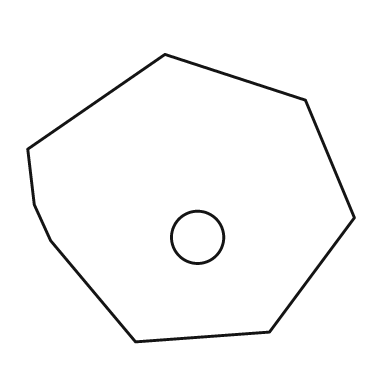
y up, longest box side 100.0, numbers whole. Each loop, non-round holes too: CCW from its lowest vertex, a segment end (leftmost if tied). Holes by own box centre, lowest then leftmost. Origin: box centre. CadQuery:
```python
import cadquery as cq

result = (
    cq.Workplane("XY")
    .moveTo(-17.0, -44.0)
    .lineTo(24.0, -41.0)
    .lineTo(50.0, -6.0)
    .lineTo(35.0, 30.0)
    .lineTo(-8.0, 44.0)
    .lineTo(-50.0, 15.0)
    .lineTo(-48.0, -2.0)
    .lineTo(-43.0, -13.0)
    .close()
    .moveTo(2.0, -12.0)
    .circle(8.0)
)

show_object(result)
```